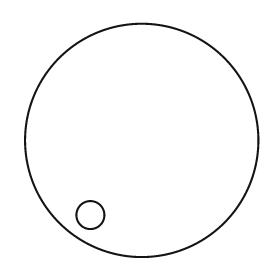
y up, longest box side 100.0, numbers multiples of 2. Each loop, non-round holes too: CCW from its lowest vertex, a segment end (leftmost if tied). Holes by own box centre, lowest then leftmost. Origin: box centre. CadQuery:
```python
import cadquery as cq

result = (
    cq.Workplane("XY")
    .moveTo(0.0, 0.0)
    .circle(50.0)
    .moveTo(-22.0, -32.0)
    .circle(6.0)
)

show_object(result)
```